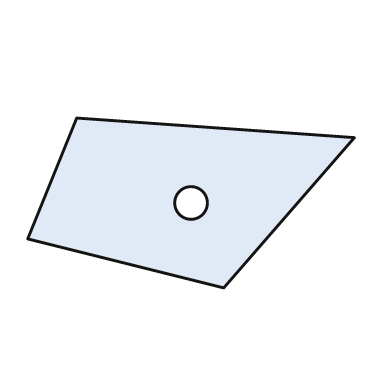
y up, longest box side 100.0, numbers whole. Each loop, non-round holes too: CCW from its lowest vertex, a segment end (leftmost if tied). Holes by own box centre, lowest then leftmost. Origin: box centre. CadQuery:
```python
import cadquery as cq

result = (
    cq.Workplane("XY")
    .moveTo(10.0, -26.0)
    .lineTo(50.0, 20.0)
    .lineTo(-35.0, 26.0)
    .lineTo(-50.0, -11.0)
    .close()
    .moveTo(0.0, 0.0)
    .circle(5.0)
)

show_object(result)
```